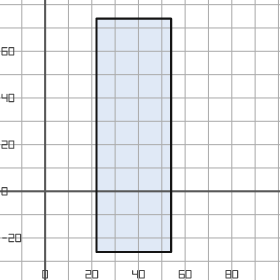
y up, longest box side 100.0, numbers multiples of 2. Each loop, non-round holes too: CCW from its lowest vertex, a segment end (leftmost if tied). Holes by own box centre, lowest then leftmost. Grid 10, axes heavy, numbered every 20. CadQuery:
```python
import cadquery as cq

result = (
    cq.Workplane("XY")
    .moveTo(22.0, -26.0)
    .lineTo(54.0, -26.0)
    .lineTo(54.0, 74.0)
    .lineTo(22.0, 74.0)
    .close()
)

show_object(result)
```